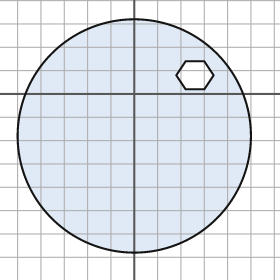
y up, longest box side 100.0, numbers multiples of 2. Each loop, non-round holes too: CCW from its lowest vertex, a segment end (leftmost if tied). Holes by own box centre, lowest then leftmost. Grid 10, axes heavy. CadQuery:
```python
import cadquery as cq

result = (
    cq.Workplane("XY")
    .moveTo(0.0, -18.0)
    .circle(50.0)
    .moveTo(22.0, 2.0)
    .lineTo(30.0, 2.0)
    .lineTo(34.0, 8.0)
    .lineTo(30.0, 14.0)
    .lineTo(22.0, 14.0)
    .lineTo(18.0, 8.0)
    .close()
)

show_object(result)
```